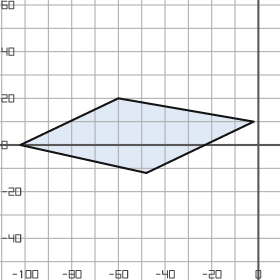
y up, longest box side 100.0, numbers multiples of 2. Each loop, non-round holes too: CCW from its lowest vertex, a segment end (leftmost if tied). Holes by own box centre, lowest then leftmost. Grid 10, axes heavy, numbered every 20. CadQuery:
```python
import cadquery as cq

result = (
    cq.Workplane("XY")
    .moveTo(-48.0, -12.0)
    .lineTo(-2.0, 10.0)
    .lineTo(-60.0, 20.0)
    .lineTo(-102.0, 0.0)
    .close()
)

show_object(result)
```